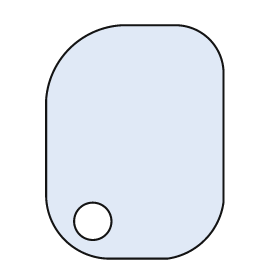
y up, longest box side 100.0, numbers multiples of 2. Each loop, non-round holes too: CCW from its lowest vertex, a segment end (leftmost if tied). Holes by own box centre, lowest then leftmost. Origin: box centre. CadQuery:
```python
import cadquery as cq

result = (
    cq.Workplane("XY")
    .moveTo(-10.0, -50.0)
    .lineTo(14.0, -50.0)
    .threePointArc((30.0, -42.0), (38.0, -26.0))
    .lineTo(38.0, 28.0)
    .threePointArc((32.0, 44.0), (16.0, 50.0))
    .lineTo(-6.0, 50.0)
    .threePointArc((-28.0, 40.0), (-38.0, 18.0))
    .lineTo(-38.0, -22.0)
    .threePointArc((-30.0, -42.0), (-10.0, -50.0))
    .close()
    .moveTo(-18.0, -34.0)
    .circle(8.0)
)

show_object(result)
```